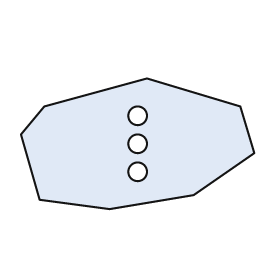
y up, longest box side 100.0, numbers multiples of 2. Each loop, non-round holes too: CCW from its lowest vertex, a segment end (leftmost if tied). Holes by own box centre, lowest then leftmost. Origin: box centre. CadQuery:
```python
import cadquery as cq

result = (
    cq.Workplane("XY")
    .moveTo(-12.0, -28.0)
    .lineTo(24.0, -22.0)
    .lineTo(50.0, -4.0)
    .lineTo(44.0, 16.0)
    .lineTo(4.0, 28.0)
    .lineTo(-40.0, 16.0)
    .lineTo(-50.0, 4.0)
    .lineTo(-42.0, -24.0)
    .close()
    .moveTo(0.0, -12.0)
    .circle(4.0)
    .moveTo(0.0, 0.0)
    .circle(4.0)
    .moveTo(0.0, 12.0)
    .circle(4.0)
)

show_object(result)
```